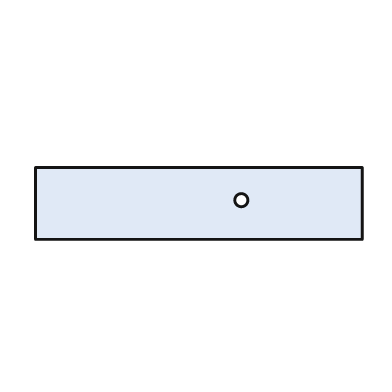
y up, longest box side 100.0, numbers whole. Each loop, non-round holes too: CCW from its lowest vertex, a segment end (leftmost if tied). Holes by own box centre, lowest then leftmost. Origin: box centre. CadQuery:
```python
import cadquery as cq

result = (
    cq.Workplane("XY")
    .moveTo(-50.0, -11.0)
    .lineTo(50.0, -11.0)
    .lineTo(50.0, 11.0)
    .lineTo(-50.0, 11.0)
    .close()
    .moveTo(13.0, 1.0)
    .circle(2.0)
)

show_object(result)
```